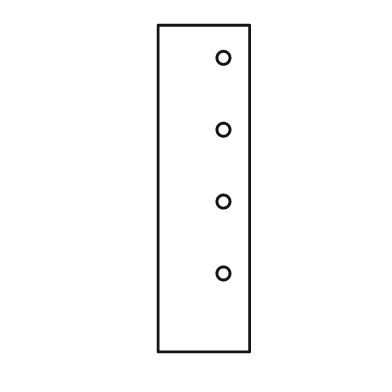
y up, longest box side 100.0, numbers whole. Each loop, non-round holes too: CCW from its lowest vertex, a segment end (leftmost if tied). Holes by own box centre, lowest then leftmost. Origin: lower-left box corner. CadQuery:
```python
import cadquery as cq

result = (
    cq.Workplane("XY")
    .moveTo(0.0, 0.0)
    .lineTo(28.0, 0.0)
    .lineTo(28.0, 100.0)
    .lineTo(0.0, 100.0)
    .close()
    .moveTo(20.0, 24.0)
    .circle(2.0)
    .moveTo(20.0, 46.0)
    .circle(2.0)
    .moveTo(20.0, 68.0)
    .circle(2.0)
    .moveTo(20.0, 90.0)
    .circle(2.0)
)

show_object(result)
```